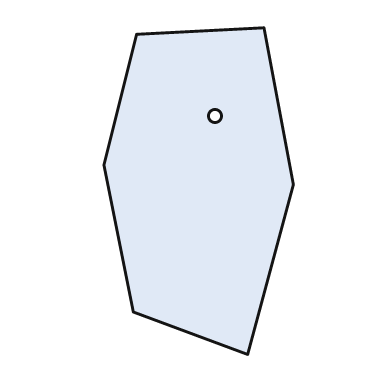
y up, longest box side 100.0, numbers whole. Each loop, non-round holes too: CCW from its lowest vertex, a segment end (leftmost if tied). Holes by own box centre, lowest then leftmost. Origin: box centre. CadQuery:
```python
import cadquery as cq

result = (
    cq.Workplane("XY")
    .moveTo(15.0, -50.0)
    .lineTo(29.0, 2.0)
    .lineTo(20.0, 50.0)
    .lineTo(-19.0, 48.0)
    .lineTo(-29.0, 8.0)
    .lineTo(-20.0, -37.0)
    .close()
    .moveTo(5.0, 23.0)
    .circle(2.0)
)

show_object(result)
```